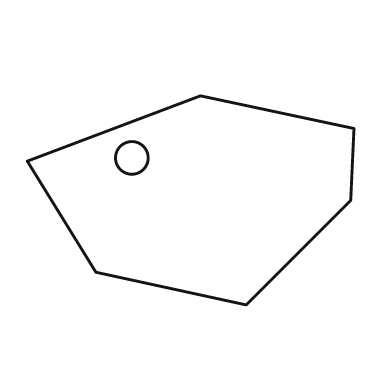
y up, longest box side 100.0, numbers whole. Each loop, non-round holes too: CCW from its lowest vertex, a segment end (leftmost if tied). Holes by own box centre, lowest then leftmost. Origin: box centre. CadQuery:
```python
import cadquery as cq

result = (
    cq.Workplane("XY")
    .moveTo(17.0, -32.0)
    .lineTo(49.0, 0.0)
    .lineTo(50.0, 22.0)
    .lineTo(3.0, 32.0)
    .lineTo(-50.0, 12.0)
    .lineTo(-29.0, -22.0)
    .close()
    .moveTo(-18.0, 13.0)
    .circle(5.0)
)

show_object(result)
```